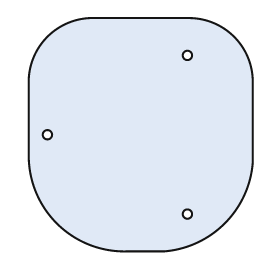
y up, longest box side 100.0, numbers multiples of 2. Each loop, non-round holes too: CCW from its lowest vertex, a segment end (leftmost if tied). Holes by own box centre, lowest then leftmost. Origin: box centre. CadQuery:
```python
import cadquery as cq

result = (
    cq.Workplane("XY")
    .moveTo(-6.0, -50.0)
    .lineTo(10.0, -50.0)
    .threePointArc((36.0, -38.0), (48.0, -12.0))
    .lineTo(48.0, 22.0)
    .threePointArc((40.0, 42.0), (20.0, 50.0))
    .lineTo(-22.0, 50.0)
    .threePointArc((-40.0, 42.0), (-48.0, 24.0))
    .lineTo(-48.0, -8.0)
    .threePointArc((-36.0, -38.0), (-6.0, -50.0))
    .close()
    .moveTo(20.0, -34.0)
    .circle(2.0)
    .moveTo(-40.0, 0.0)
    .circle(2.0)
    .moveTo(20.0, 34.0)
    .circle(2.0)
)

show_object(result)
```